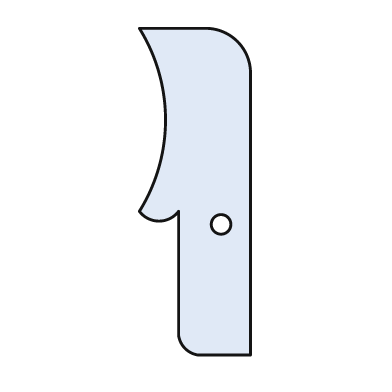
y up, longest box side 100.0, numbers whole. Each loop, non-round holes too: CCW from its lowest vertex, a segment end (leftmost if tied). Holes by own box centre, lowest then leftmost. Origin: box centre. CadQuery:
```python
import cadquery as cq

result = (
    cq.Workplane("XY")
    .moveTo(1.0, -50.0)
    .lineTo(17.0, -50.0)
    .lineTo(17.0, 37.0)
    .threePointArc((13.0, 46.0), (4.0, 50.0))
    .lineTo(-17.0, 50.0)
    .threePointArc((-9.0, 22.0), (-17.0, -6.0))
    .threePointArc((-11.0, -9.0), (-5.0, -6.0))
    .lineTo(-5.0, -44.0)
    .threePointArc((-3.0, -48.0), (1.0, -50.0))
    .close()
    .moveTo(8.0, -10.0)
    .circle(3.0)
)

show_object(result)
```